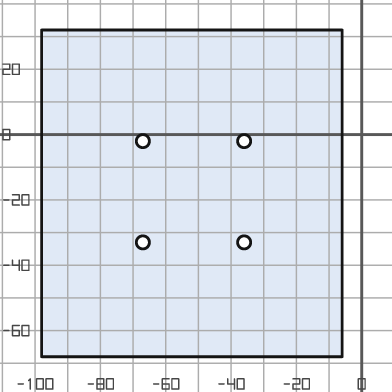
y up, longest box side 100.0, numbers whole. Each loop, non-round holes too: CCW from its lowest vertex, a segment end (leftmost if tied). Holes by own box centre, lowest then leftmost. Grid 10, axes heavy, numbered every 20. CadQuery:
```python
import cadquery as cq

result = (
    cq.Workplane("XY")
    .moveTo(-98.0, -68.0)
    .lineTo(-6.0, -68.0)
    .lineTo(-6.0, 32.0)
    .lineTo(-98.0, 32.0)
    .close()
    .moveTo(-67.0, -33.0)
    .circle(2.0)
    .moveTo(-36.0, -33.0)
    .circle(2.0)
    .moveTo(-67.0, -2.0)
    .circle(2.0)
    .moveTo(-36.0, -2.0)
    .circle(2.0)
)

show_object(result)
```